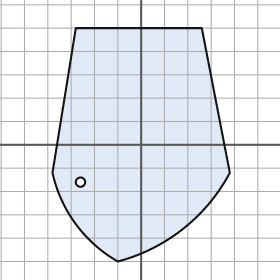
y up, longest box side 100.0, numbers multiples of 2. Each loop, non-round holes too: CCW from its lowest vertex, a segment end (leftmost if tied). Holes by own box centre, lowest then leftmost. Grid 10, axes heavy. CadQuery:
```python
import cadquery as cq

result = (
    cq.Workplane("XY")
    .moveTo(-10.0, -50.0)
    .threePointArc((18.0, -36.0), (38.0, -12.0))
    .lineTo(26.0, 50.0)
    .lineTo(-28.0, 50.0)
    .lineTo(-38.0, -12.0)
    .threePointArc((-28.0, -34.0), (-10.0, -50.0))
    .close()
    .moveTo(-26.0, -16.0)
    .circle(2.0)
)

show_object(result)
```